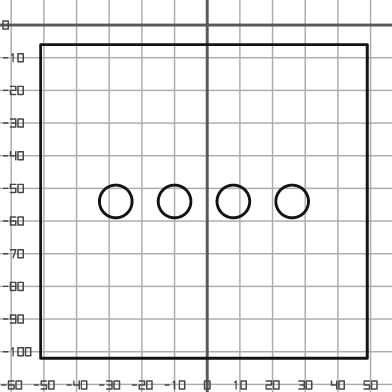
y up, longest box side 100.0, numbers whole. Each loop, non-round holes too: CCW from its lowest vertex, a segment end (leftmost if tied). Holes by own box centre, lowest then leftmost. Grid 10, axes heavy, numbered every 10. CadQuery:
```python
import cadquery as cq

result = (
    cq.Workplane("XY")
    .moveTo(-51.0, -102.0)
    .lineTo(49.0, -102.0)
    .lineTo(49.0, -6.0)
    .lineTo(-51.0, -6.0)
    .close()
    .moveTo(-28.0, -54.0)
    .circle(5.0)
    .moveTo(-10.0, -54.0)
    .circle(5.0)
    .moveTo(8.0, -54.0)
    .circle(5.0)
    .moveTo(26.0, -54.0)
    .circle(5.0)
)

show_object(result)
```